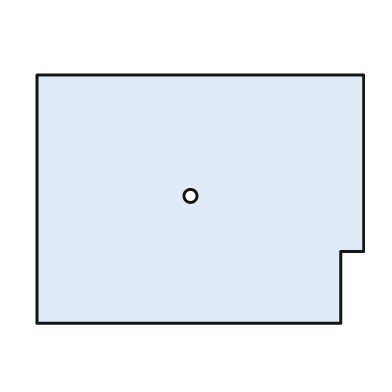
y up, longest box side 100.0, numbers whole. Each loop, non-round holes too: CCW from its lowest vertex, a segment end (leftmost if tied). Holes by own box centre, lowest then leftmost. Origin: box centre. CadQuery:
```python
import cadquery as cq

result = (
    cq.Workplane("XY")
    .moveTo(-50.0, -38.0)
    .lineTo(43.0, -38.0)
    .lineTo(43.0, -16.0)
    .lineTo(50.0, -16.0)
    .lineTo(50.0, 38.0)
    .lineTo(-50.0, 38.0)
    .close()
    .moveTo(-3.0, 1.0)
    .circle(2.0)
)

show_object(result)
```